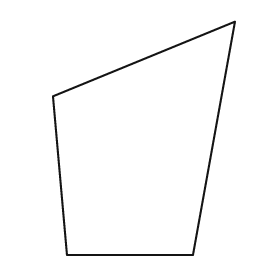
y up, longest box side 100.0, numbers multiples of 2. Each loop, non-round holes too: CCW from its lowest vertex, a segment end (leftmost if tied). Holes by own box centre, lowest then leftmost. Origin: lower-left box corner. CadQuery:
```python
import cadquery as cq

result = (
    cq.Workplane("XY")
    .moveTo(6.0, 0.0)
    .lineTo(60.0, 0.0)
    .lineTo(78.0, 100.0)
    .lineTo(0.0, 68.0)
    .close()
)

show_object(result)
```